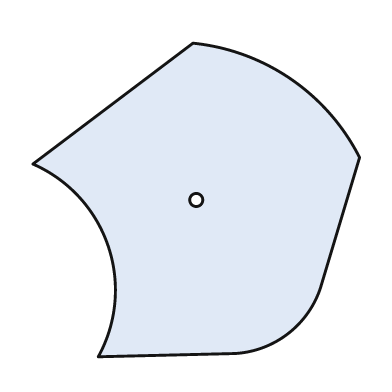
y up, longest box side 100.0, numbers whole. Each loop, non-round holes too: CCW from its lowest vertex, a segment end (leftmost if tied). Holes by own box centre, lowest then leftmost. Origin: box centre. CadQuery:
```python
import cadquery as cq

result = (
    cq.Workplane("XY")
    .moveTo(-30.0, -48.0)
    .lineTo(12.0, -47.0)
    .threePointArc((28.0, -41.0), (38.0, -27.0))
    .lineTo(50.0, 13.0)
    .threePointArc((29.0, 37.0), (-1.0, 48.0))
    .lineTo(-50.0, 11.0)
    .threePointArc((-27.0, -14.0), (-30.0, -48.0))
    .close()
    .moveTo(0.0, 0.0)
    .circle(2.0)
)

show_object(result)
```